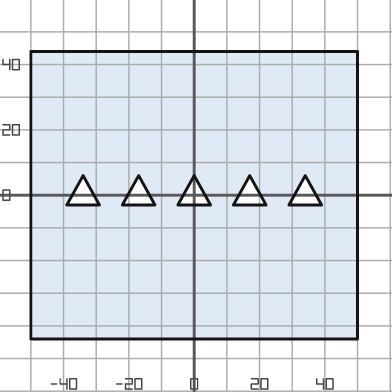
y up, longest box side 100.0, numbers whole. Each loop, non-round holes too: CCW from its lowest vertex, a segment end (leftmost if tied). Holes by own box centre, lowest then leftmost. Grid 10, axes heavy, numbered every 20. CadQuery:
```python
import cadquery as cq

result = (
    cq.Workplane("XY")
    .moveTo(-50.0, -44.0)
    .lineTo(50.0, -44.0)
    .lineTo(50.0, 44.0)
    .lineTo(-50.0, 44.0)
    .close()
    .moveTo(-39.0, -3.0)
    .lineTo(-29.0, -3.0)
    .lineTo(-34.0, 6.0)
    .close()
    .moveTo(-22.0, -3.0)
    .lineTo(-12.0, -3.0)
    .lineTo(-17.0, 6.0)
    .close()
    .moveTo(-5.0, -3.0)
    .lineTo(5.0, -3.0)
    .lineTo(0.0, 6.0)
    .close()
    .moveTo(12.0, -3.0)
    .lineTo(22.0, -3.0)
    .lineTo(17.0, 6.0)
    .close()
    .moveTo(29.0, -3.0)
    .lineTo(39.0, -3.0)
    .lineTo(34.0, 6.0)
    .close()
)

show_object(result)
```